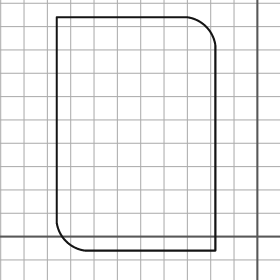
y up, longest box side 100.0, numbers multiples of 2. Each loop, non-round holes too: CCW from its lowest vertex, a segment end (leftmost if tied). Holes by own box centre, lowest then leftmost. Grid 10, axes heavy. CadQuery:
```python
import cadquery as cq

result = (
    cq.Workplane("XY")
    .moveTo(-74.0, -6.0)
    .lineTo(-18.0, -6.0)
    .lineTo(-18.0, 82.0)
    .threePointArc((-22.0, 90.0), (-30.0, 94.0))
    .lineTo(-86.0, 94.0)
    .lineTo(-86.0, 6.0)
    .threePointArc((-82.0, -2.0), (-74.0, -6.0))
    .close()
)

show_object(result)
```